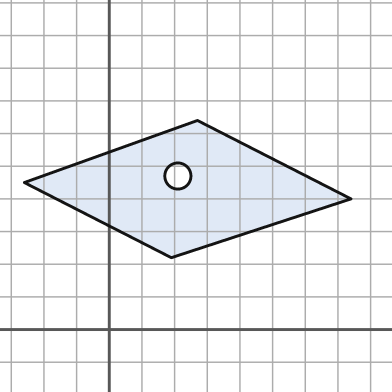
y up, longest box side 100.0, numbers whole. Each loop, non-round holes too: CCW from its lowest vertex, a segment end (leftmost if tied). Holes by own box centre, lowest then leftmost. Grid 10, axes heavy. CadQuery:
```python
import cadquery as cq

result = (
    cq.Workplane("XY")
    .moveTo(19.0, 22.0)
    .lineTo(74.0, 40.0)
    .lineTo(27.0, 64.0)
    .lineTo(-26.0, 45.0)
    .close()
    .moveTo(21.0, 47.0)
    .circle(4.0)
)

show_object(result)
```